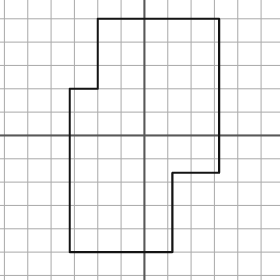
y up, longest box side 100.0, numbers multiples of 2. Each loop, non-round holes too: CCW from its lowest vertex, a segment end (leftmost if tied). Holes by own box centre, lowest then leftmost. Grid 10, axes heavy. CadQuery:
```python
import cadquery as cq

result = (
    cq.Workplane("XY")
    .moveTo(-32.0, -50.0)
    .lineTo(12.0, -50.0)
    .lineTo(12.0, -16.0)
    .lineTo(32.0, -16.0)
    .lineTo(32.0, 50.0)
    .lineTo(-20.0, 50.0)
    .lineTo(-20.0, 20.0)
    .lineTo(-32.0, 20.0)
    .close()
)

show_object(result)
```